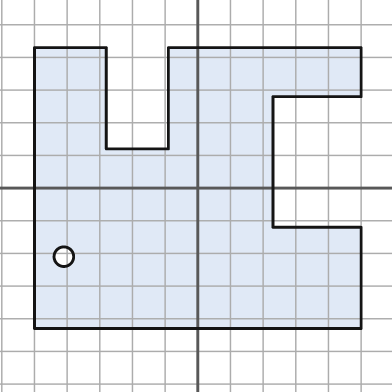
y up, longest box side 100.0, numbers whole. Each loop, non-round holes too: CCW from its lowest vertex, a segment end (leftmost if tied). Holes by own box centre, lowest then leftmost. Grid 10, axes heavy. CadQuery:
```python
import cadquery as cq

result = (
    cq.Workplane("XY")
    .moveTo(-50.0, -43.0)
    .lineTo(50.0, -43.0)
    .lineTo(50.0, -12.0)
    .lineTo(23.0, -12.0)
    .lineTo(23.0, 28.0)
    .lineTo(50.0, 28.0)
    .lineTo(50.0, 43.0)
    .lineTo(-9.0, 43.0)
    .lineTo(-9.0, 12.0)
    .lineTo(-28.0, 12.0)
    .lineTo(-28.0, 43.0)
    .lineTo(-50.0, 43.0)
    .close()
    .moveTo(-41.0, -21.0)
    .circle(3.0)
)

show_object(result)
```